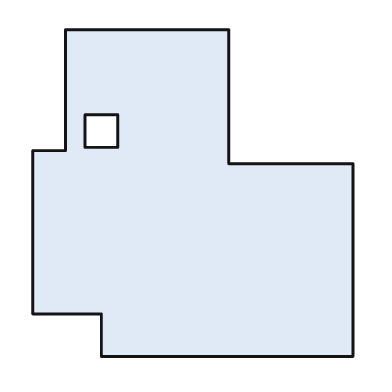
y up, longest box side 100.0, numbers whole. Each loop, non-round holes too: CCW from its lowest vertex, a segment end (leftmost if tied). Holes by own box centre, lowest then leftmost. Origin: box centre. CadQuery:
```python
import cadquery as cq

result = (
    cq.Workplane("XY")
    .moveTo(-28.0, -50.0)
    .lineTo(49.0, -50.0)
    .lineTo(49.0, 9.0)
    .lineTo(11.0, 9.0)
    .lineTo(11.0, 50.0)
    .lineTo(-39.0, 50.0)
    .lineTo(-39.0, 13.0)
    .lineTo(-49.0, 13.0)
    .lineTo(-49.0, -37.0)
    .lineTo(-28.0, -37.0)
    .close()
    .moveTo(-33.0, 14.0)
    .lineTo(-23.0, 14.0)
    .lineTo(-23.0, 24.0)
    .lineTo(-33.0, 24.0)
    .close()
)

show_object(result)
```